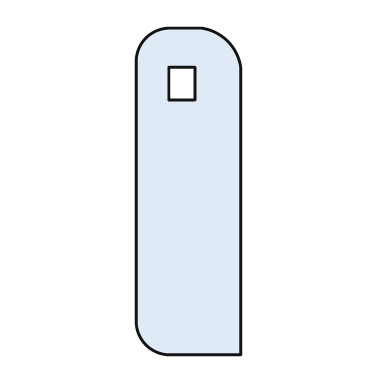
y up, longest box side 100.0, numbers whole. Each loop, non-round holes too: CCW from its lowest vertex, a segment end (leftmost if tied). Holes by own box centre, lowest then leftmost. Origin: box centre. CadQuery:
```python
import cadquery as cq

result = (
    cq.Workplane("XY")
    .moveTo(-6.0, -50.0)
    .lineTo(16.0, -50.0)
    .lineTo(16.0, 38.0)
    .threePointArc((12.0, 46.0), (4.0, 50.0))
    .lineTo(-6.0, 50.0)
    .threePointArc((-13.0, 47.0), (-16.0, 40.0))
    .lineTo(-16.0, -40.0)
    .threePointArc((-13.0, -47.0), (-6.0, -50.0))
    .close()
    .moveTo(-6.0, 28.0)
    .lineTo(2.0, 28.0)
    .lineTo(2.0, 38.0)
    .lineTo(-6.0, 38.0)
    .close()
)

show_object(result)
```